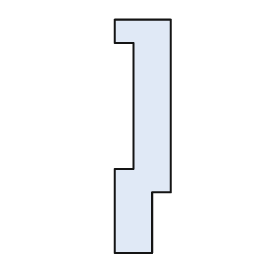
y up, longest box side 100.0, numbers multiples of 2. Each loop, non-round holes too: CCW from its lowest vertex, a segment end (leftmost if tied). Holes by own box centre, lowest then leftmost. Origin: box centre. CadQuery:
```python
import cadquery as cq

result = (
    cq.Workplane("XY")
    .moveTo(-12.0, -50.0)
    .lineTo(4.0, -50.0)
    .lineTo(4.0, -24.0)
    .lineTo(12.0, -24.0)
    .lineTo(12.0, 50.0)
    .lineTo(-12.0, 50.0)
    .lineTo(-12.0, 40.0)
    .lineTo(-4.0, 40.0)
    .lineTo(-4.0, -14.0)
    .lineTo(-12.0, -14.0)
    .close()
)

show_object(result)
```